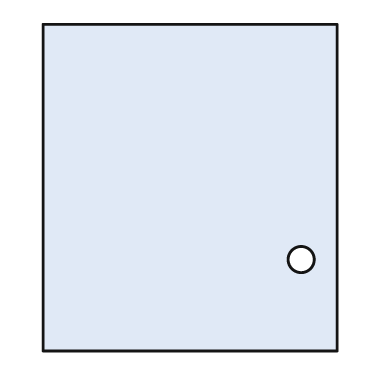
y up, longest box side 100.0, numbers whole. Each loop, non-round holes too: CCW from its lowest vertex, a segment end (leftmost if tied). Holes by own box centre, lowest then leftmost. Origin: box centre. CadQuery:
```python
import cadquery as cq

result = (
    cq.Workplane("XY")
    .moveTo(-45.0, -50.0)
    .lineTo(45.0, -50.0)
    .lineTo(45.0, 50.0)
    .lineTo(-45.0, 50.0)
    .close()
    .moveTo(34.0, -22.0)
    .circle(4.0)
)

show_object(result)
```